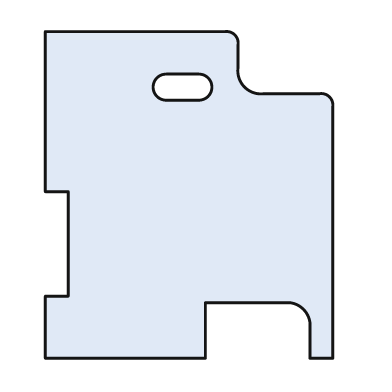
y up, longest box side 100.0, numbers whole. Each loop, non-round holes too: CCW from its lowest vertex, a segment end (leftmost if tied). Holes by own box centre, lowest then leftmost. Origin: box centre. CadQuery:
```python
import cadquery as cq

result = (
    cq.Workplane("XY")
    .moveTo(-44.0, -50.0)
    .lineTo(5.0, -50.0)
    .lineTo(5.0, -33.0)
    .lineTo(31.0, -33.0)
    .threePointArc((35.0, -35.0), (37.0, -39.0))
    .lineTo(37.0, -50.0)
    .lineTo(44.0, -50.0)
    .lineTo(44.0, 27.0)
    .threePointArc((43.0, 30.0), (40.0, 31.0))
    .lineTo(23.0, 31.0)
    .threePointArc((17.0, 33.0), (15.0, 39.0))
    .lineTo(15.0, 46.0)
    .threePointArc((14.0, 49.0), (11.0, 50.0))
    .lineTo(-44.0, 50.0)
    .lineTo(-44.0, 1.0)
    .lineTo(-37.0, 1.0)
    .lineTo(-37.0, -31.0)
    .lineTo(-44.0, -31.0)
    .close()
    .moveTo(-7.0, 29.0)
    .lineTo(3.0, 29.0)
    .threePointArc((7.0, 33.0), (3.0, 37.0))
    .lineTo(-7.0, 37.0)
    .threePointArc((-11.0, 33.0), (-7.0, 29.0))
    .close()
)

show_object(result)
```